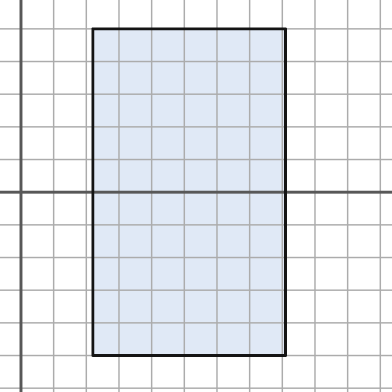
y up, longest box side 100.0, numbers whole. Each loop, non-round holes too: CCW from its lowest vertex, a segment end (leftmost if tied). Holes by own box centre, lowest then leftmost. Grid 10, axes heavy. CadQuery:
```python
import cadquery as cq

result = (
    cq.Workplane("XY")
    .moveTo(22.0, -50.0)
    .lineTo(81.0, -50.0)
    .lineTo(81.0, 50.0)
    .lineTo(22.0, 50.0)
    .close()
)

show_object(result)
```